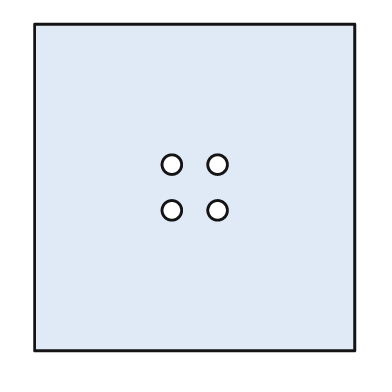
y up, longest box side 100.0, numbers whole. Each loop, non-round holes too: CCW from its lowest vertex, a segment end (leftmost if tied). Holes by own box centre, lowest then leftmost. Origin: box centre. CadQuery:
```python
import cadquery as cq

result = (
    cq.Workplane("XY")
    .moveTo(-49.0, -50.0)
    .lineTo(49.0, -50.0)
    .lineTo(49.0, 50.0)
    .lineTo(-49.0, 50.0)
    .close()
    .moveTo(-7.0, -7.0)
    .circle(3.0)
    .moveTo(7.0, -7.0)
    .circle(3.0)
    .moveTo(-7.0, 7.0)
    .circle(3.0)
    .moveTo(7.0, 7.0)
    .circle(3.0)
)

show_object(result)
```